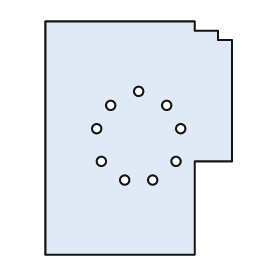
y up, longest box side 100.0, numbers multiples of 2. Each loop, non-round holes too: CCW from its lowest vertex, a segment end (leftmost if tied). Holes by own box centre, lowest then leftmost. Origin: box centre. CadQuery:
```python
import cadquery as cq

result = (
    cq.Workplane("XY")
    .moveTo(-40.0, -50.0)
    .lineTo(24.0, -50.0)
    .lineTo(24.0, -10.0)
    .lineTo(40.0, -10.0)
    .lineTo(40.0, 42.0)
    .lineTo(34.0, 42.0)
    .lineTo(34.0, 46.0)
    .lineTo(24.0, 46.0)
    .lineTo(24.0, 50.0)
    .lineTo(-40.0, 50.0)
    .close()
    .moveTo(-6.0, -18.0)
    .circle(2.0)
    .moveTo(6.0, -18.0)
    .circle(2.0)
    .moveTo(-16.0, -10.0)
    .circle(2.0)
    .moveTo(16.0, -10.0)
    .circle(2.0)
    .moveTo(-18.0, 4.0)
    .circle(2.0)
    .moveTo(18.0, 4.0)
    .circle(2.0)
    .moveTo(-12.0, 14.0)
    .circle(2.0)
    .moveTo(12.0, 14.0)
    .circle(2.0)
    .moveTo(0.0, 20.0)
    .circle(2.0)
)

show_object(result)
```